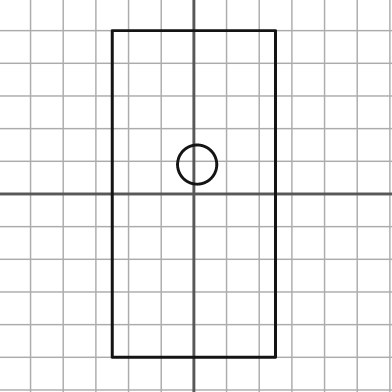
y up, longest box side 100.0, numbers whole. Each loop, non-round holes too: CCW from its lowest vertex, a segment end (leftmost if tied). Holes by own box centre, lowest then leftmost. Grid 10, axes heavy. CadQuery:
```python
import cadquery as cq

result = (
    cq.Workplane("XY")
    .moveTo(-25.0, -50.0)
    .lineTo(25.0, -50.0)
    .lineTo(25.0, 50.0)
    .lineTo(-25.0, 50.0)
    .close()
    .moveTo(1.0, 9.0)
    .circle(6.0)
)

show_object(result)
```